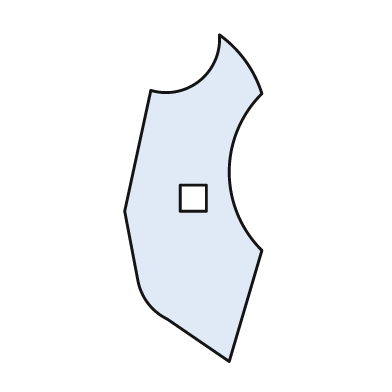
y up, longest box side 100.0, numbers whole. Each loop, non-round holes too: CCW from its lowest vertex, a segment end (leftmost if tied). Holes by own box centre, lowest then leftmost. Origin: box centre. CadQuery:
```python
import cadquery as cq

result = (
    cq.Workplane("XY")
    .moveTo(11.0, -50.0)
    .lineTo(21.0, -16.0)
    .threePointArc((11.0, 8.0), (21.0, 32.0))
    .threePointArc((16.0, 42.0), (8.0, 50.0))
    .threePointArc((2.0, 36.0), (-13.0, 33.0))
    .lineTo(-21.0, -4.0)
    .lineTo(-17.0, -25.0)
    .threePointArc((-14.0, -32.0), (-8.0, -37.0))
    .close()
    .moveTo(-4.0, -4.0)
    .lineTo(4.0, -4.0)
    .lineTo(4.0, 4.0)
    .lineTo(-4.0, 4.0)
    .close()
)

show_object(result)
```